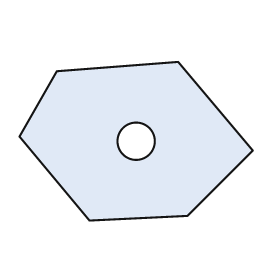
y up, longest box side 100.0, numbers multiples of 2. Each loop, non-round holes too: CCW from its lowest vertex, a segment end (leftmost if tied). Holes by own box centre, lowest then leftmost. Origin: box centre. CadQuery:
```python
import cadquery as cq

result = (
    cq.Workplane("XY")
    .moveTo(-20.0, -34.0)
    .lineTo(22.0, -32.0)
    .lineTo(50.0, -4.0)
    .lineTo(18.0, 34.0)
    .lineTo(-34.0, 30.0)
    .lineTo(-50.0, 2.0)
    .close()
    .moveTo(0.0, 0.0)
    .circle(8.0)
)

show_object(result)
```